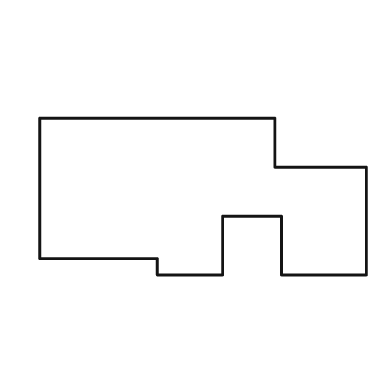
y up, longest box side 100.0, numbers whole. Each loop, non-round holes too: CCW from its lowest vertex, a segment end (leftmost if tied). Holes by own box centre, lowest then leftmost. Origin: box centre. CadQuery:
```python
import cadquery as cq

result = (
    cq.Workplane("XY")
    .moveTo(-14.0, -24.0)
    .lineTo(6.0, -24.0)
    .lineTo(6.0, -6.0)
    .lineTo(24.0, -6.0)
    .lineTo(24.0, -24.0)
    .lineTo(50.0, -24.0)
    .lineTo(50.0, 9.0)
    .lineTo(22.0, 9.0)
    .lineTo(22.0, 24.0)
    .lineTo(-50.0, 24.0)
    .lineTo(-50.0, -19.0)
    .lineTo(-14.0, -19.0)
    .close()
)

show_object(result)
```